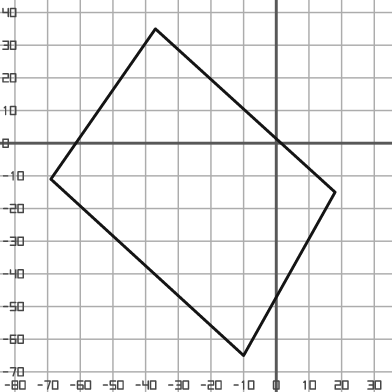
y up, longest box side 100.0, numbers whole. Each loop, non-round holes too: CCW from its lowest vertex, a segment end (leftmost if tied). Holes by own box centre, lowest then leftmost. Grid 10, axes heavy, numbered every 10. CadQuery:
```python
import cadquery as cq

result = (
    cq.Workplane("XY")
    .moveTo(-10.0, -65.0)
    .lineTo(18.0, -15.0)
    .lineTo(-37.0, 35.0)
    .lineTo(-69.0, -11.0)
    .close()
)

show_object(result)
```